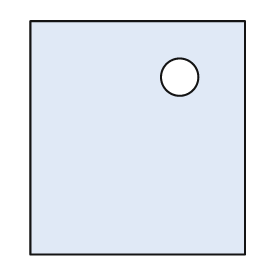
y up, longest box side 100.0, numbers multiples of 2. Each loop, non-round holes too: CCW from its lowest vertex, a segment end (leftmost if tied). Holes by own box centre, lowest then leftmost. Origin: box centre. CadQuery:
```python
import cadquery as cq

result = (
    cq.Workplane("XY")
    .moveTo(-46.0, -50.0)
    .lineTo(46.0, -50.0)
    .lineTo(46.0, 50.0)
    .lineTo(-46.0, 50.0)
    .close()
    .moveTo(18.0, 26.0)
    .circle(8.0)
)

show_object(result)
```